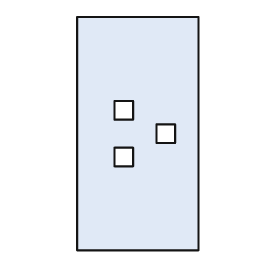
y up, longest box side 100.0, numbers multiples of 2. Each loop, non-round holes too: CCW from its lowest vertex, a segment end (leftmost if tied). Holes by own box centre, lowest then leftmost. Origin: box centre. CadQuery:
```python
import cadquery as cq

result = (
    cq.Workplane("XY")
    .moveTo(-26.0, -50.0)
    .lineTo(26.0, -50.0)
    .lineTo(26.0, 50.0)
    .lineTo(-26.0, 50.0)
    .close()
    .moveTo(-10.0, -14.0)
    .lineTo(-2.0, -14.0)
    .lineTo(-2.0, -6.0)
    .lineTo(-10.0, -6.0)
    .close()
    .moveTo(8.0, -4.0)
    .lineTo(16.0, -4.0)
    .lineTo(16.0, 4.0)
    .lineTo(8.0, 4.0)
    .close()
    .moveTo(-10.0, 6.0)
    .lineTo(-2.0, 6.0)
    .lineTo(-2.0, 14.0)
    .lineTo(-10.0, 14.0)
    .close()
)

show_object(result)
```